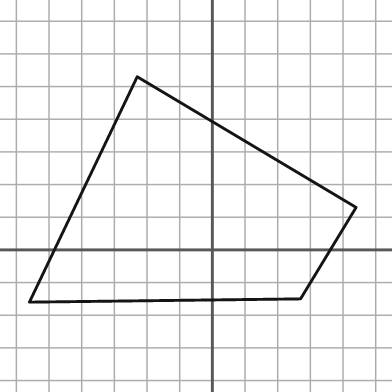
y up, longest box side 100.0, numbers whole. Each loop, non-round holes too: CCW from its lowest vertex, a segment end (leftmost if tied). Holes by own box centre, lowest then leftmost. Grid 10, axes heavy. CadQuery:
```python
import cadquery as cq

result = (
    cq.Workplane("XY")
    .moveTo(-56.0, -16.0)
    .lineTo(27.0, -15.0)
    .lineTo(44.0, 13.0)
    .lineTo(-23.0, 53.0)
    .close()
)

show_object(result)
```